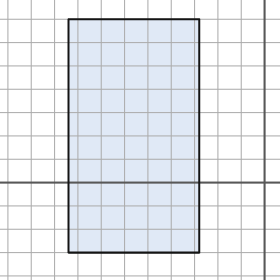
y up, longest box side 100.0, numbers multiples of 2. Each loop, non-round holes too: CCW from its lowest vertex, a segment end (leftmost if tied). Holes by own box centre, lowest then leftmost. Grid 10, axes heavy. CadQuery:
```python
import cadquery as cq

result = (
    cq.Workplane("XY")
    .moveTo(-84.0, -30.0)
    .lineTo(-28.0, -30.0)
    .lineTo(-28.0, 70.0)
    .lineTo(-84.0, 70.0)
    .close()
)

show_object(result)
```